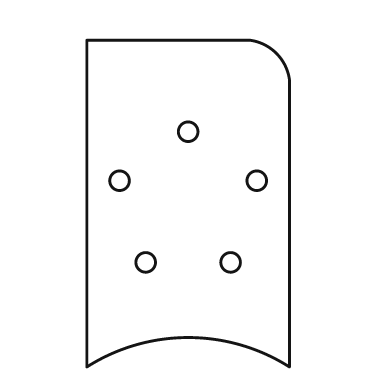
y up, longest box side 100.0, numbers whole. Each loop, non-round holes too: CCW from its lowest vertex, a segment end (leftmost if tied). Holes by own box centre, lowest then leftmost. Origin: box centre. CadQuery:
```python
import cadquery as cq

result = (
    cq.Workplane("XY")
    .moveTo(-31.0, -50.0)
    .threePointArc((0.0, -41.0), (31.0, -50.0))
    .lineTo(31.0, 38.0)
    .threePointArc((27.0, 46.0), (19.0, 50.0))
    .lineTo(-31.0, 50.0)
    .close()
    .moveTo(-13.0, -18.0)
    .circle(3.0)
    .moveTo(13.0, -18.0)
    .circle(3.0)
    .moveTo(-21.0, 7.0)
    .circle(3.0)
    .moveTo(21.0, 7.0)
    .circle(3.0)
    .moveTo(0.0, 22.0)
    .circle(3.0)
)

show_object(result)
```